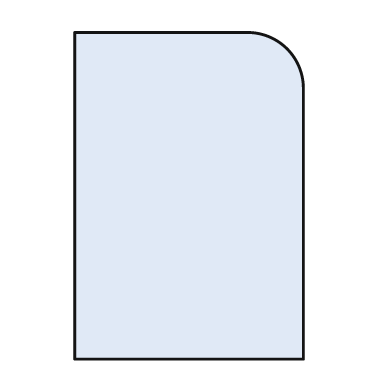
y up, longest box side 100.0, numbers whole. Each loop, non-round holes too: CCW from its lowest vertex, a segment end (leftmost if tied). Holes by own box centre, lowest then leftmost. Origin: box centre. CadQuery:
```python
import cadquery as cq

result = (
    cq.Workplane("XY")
    .moveTo(-35.0, -50.0)
    .lineTo(35.0, -50.0)
    .lineTo(35.0, 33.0)
    .threePointArc((30.0, 45.0), (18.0, 50.0))
    .lineTo(-35.0, 50.0)
    .close()
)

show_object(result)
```